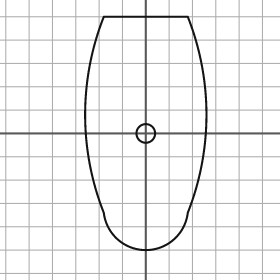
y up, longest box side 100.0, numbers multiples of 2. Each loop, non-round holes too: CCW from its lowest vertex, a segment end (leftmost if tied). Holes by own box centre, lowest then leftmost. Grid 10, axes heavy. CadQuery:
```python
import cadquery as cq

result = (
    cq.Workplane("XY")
    .moveTo(-18.0, -34.0)
    .threePointArc((0.0, -50.0), (18.0, -34.0))
    .threePointArc((26.0, 8.0), (18.0, 50.0))
    .lineTo(-18.0, 50.0)
    .threePointArc((-26.0, 8.0), (-18.0, -34.0))
    .close()
    .moveTo(0.0, 0.0)
    .circle(4.0)
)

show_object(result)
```